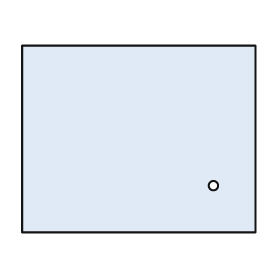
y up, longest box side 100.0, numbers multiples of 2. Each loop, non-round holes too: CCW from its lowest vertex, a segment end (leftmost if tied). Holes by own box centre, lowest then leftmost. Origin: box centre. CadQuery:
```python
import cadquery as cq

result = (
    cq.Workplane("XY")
    .moveTo(-50.0, -40.0)
    .lineTo(50.0, -40.0)
    .lineTo(50.0, 40.0)
    .lineTo(-50.0, 40.0)
    .close()
    .moveTo(32.0, -20.0)
    .circle(2.0)
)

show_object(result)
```